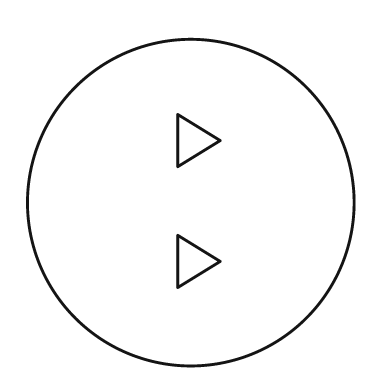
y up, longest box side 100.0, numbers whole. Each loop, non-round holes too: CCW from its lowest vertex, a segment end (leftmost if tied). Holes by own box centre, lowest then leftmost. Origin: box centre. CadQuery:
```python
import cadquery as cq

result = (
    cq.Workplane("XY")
    .moveTo(0.0, 0.0)
    .circle(50.0)
    .moveTo(-4.0, -26.0)
    .lineTo(9.0, -18.0)
    .lineTo(-4.0, -10.0)
    .close()
    .moveTo(-4.0, 11.0)
    .lineTo(9.0, 19.0)
    .lineTo(-4.0, 27.0)
    .close()
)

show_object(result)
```